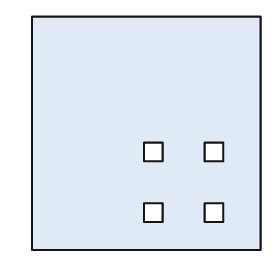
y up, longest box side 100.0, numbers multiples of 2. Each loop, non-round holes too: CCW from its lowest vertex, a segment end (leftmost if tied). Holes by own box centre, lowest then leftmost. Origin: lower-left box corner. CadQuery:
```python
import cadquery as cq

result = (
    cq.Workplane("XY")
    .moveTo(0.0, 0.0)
    .lineTo(98.0, 0.0)
    .lineTo(98.0, 100.0)
    .lineTo(0.0, 100.0)
    .close()
    .moveTo(48.0, 12.0)
    .lineTo(56.0, 12.0)
    .lineTo(56.0, 20.0)
    .lineTo(48.0, 20.0)
    .close()
    .moveTo(74.0, 12.0)
    .lineTo(82.0, 12.0)
    .lineTo(82.0, 20.0)
    .lineTo(74.0, 20.0)
    .close()
    .moveTo(48.0, 38.0)
    .lineTo(56.0, 38.0)
    .lineTo(56.0, 46.0)
    .lineTo(48.0, 46.0)
    .close()
    .moveTo(74.0, 38.0)
    .lineTo(82.0, 38.0)
    .lineTo(82.0, 46.0)
    .lineTo(74.0, 46.0)
    .close()
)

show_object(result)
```